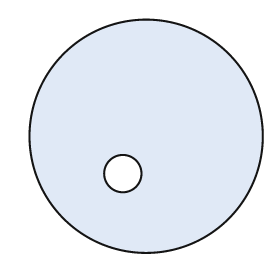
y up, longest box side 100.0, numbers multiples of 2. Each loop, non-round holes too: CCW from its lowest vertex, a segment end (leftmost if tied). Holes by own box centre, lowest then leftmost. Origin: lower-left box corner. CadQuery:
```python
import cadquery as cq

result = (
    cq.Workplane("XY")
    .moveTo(50.0, 50.0)
    .circle(50.0)
    .moveTo(40.0, 34.0)
    .circle(8.0)
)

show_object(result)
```